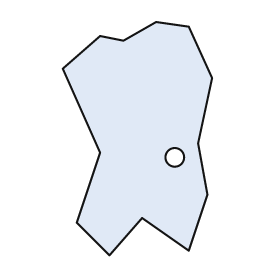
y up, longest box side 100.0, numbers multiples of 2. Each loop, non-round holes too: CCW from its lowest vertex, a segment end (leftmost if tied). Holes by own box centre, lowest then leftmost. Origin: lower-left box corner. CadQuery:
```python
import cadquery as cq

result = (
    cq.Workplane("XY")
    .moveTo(20.0, 0.0)
    .lineTo(34.0, 16.0)
    .lineTo(54.0, 2.0)
    .lineTo(62.0, 26.0)
    .lineTo(58.0, 48.0)
    .lineTo(64.0, 76.0)
    .lineTo(54.0, 98.0)
    .lineTo(40.0, 100.0)
    .lineTo(26.0, 92.0)
    .lineTo(16.0, 94.0)
    .lineTo(0.0, 80.0)
    .lineTo(16.0, 44.0)
    .lineTo(6.0, 14.0)
    .close()
    .moveTo(48.0, 42.0)
    .circle(4.0)
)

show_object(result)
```